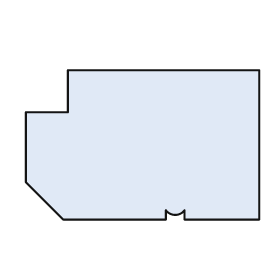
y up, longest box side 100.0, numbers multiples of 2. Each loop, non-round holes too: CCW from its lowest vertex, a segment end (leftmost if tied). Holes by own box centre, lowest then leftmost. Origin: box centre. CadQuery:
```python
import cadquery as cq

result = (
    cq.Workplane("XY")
    .moveTo(-34.0, -32.0)
    .lineTo(10.0, -32.0)
    .lineTo(10.0, -28.0)
    .threePointArc((14.0, -30.0), (18.0, -28.0))
    .lineTo(18.0, -32.0)
    .lineTo(50.0, -32.0)
    .lineTo(50.0, 32.0)
    .lineTo(-32.0, 32.0)
    .lineTo(-32.0, 14.0)
    .lineTo(-50.0, 14.0)
    .lineTo(-50.0, -16.0)
    .close()
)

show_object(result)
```